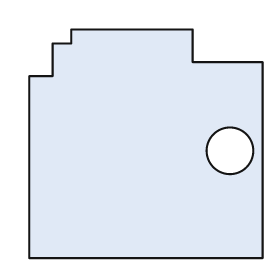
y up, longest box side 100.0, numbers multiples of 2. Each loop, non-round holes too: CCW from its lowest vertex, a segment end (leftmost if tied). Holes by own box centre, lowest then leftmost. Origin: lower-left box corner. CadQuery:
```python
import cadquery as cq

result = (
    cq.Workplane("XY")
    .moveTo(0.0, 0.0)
    .lineTo(100.0, 0.0)
    .lineTo(100.0, 84.0)
    .lineTo(70.0, 84.0)
    .lineTo(70.0, 98.0)
    .lineTo(18.0, 98.0)
    .lineTo(18.0, 92.0)
    .lineTo(10.0, 92.0)
    .lineTo(10.0, 78.0)
    .lineTo(0.0, 78.0)
    .close()
    .moveTo(86.0, 46.0)
    .circle(10.0)
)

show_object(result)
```